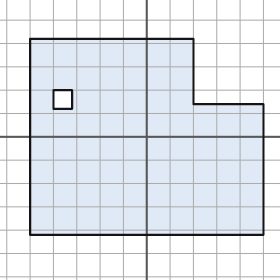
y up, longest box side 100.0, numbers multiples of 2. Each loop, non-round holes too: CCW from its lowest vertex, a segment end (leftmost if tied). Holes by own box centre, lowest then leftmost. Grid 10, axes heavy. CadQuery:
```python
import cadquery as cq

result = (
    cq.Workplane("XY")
    .moveTo(-50.0, -42.0)
    .lineTo(50.0, -42.0)
    .lineTo(50.0, 14.0)
    .lineTo(20.0, 14.0)
    .lineTo(20.0, 42.0)
    .lineTo(-50.0, 42.0)
    .close()
    .moveTo(-40.0, 12.0)
    .lineTo(-32.0, 12.0)
    .lineTo(-32.0, 20.0)
    .lineTo(-40.0, 20.0)
    .close()
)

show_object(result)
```